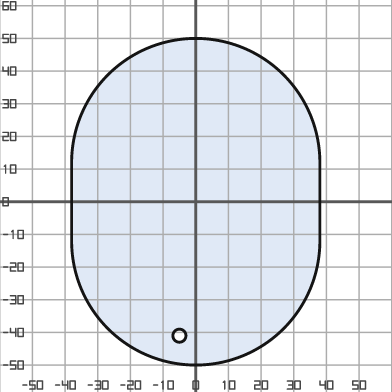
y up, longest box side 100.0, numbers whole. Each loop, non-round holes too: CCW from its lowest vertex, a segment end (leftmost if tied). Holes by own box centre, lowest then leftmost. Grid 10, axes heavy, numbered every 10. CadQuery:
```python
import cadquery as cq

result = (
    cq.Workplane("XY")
    .moveTo(-38.0, -12.0)
    .threePointArc((0.0, -50.0), (38.0, -12.0))
    .lineTo(38.0, 12.0)
    .threePointArc((0.0, 50.0), (-38.0, 12.0))
    .close()
    .moveTo(-5.0, -41.0)
    .circle(2.0)
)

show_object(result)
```